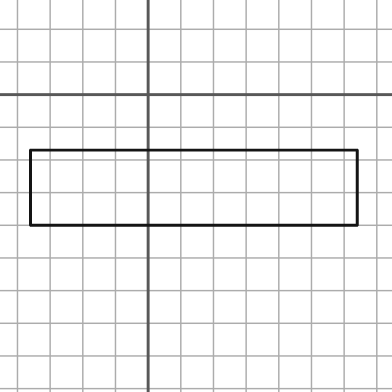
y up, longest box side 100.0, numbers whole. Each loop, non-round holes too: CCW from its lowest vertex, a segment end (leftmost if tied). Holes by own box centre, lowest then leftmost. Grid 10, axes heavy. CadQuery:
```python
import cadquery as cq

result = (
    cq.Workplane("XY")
    .moveTo(-36.0, -40.0)
    .lineTo(64.0, -40.0)
    .lineTo(64.0, -17.0)
    .lineTo(-36.0, -17.0)
    .close()
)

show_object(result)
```